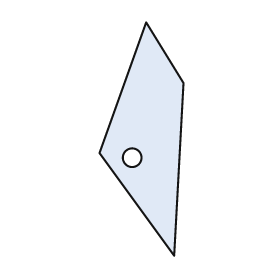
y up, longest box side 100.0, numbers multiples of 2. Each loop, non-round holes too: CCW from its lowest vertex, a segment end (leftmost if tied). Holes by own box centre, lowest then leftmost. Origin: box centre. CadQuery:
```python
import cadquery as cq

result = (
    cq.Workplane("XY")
    .moveTo(14.0, -50.0)
    .lineTo(18.0, 24.0)
    .lineTo(2.0, 50.0)
    .lineTo(-18.0, -6.0)
    .close()
    .moveTo(-4.0, -8.0)
    .circle(4.0)
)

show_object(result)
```